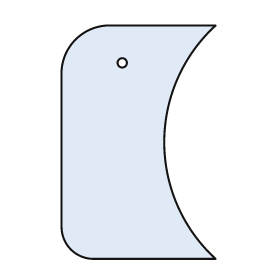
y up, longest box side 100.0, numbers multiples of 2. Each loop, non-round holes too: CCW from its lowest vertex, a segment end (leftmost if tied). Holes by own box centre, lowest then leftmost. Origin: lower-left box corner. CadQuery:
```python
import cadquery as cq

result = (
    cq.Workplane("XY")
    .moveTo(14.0, 0.0)
    .lineTo(66.0, 0.0)
    .threePointArc((44.0, 50.0), (66.0, 100.0))
    .lineTo(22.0, 100.0)
    .threePointArc((6.0, 94.0), (0.0, 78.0))
    .lineTo(0.0, 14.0)
    .threePointArc((4.0, 4.0), (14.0, 0.0))
    .close()
    .moveTo(26.0, 84.0)
    .circle(2.0)
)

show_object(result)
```